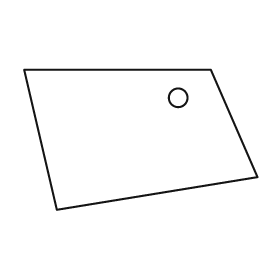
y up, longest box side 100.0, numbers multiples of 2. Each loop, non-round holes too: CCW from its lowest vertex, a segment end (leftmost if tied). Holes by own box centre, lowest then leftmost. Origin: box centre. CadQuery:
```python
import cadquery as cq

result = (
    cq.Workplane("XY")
    .moveTo(-36.0, -30.0)
    .lineTo(50.0, -16.0)
    .lineTo(30.0, 30.0)
    .lineTo(-50.0, 30.0)
    .close()
    .moveTo(16.0, 18.0)
    .circle(4.0)
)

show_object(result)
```